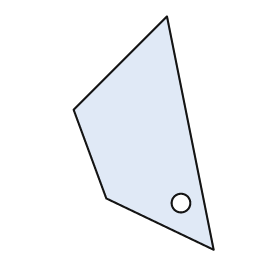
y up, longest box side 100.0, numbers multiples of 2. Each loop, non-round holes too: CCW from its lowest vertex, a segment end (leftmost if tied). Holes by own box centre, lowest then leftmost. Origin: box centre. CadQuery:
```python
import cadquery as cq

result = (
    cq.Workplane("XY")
    .moveTo(30.0, -50.0)
    .lineTo(10.0, 50.0)
    .lineTo(-30.0, 10.0)
    .lineTo(-16.0, -28.0)
    .close()
    .moveTo(16.0, -30.0)
    .circle(4.0)
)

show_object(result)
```